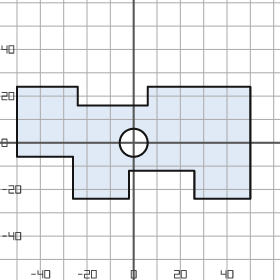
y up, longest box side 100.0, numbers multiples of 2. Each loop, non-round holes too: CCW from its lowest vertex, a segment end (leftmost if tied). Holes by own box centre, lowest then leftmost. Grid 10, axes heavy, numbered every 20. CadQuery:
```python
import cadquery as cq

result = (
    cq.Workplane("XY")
    .moveTo(-26.0, -24.0)
    .lineTo(-2.0, -24.0)
    .lineTo(-2.0, -12.0)
    .lineTo(26.0, -12.0)
    .lineTo(26.0, -24.0)
    .lineTo(50.0, -24.0)
    .lineTo(50.0, 24.0)
    .lineTo(6.0, 24.0)
    .lineTo(6.0, 16.0)
    .lineTo(-24.0, 16.0)
    .lineTo(-24.0, 24.0)
    .lineTo(-50.0, 24.0)
    .lineTo(-50.0, -6.0)
    .lineTo(-26.0, -6.0)
    .close()
    .moveTo(0.0, 0.0)
    .circle(6.0)
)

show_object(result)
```